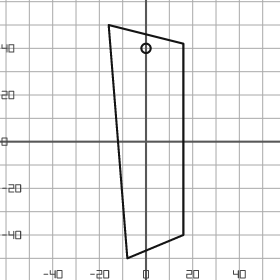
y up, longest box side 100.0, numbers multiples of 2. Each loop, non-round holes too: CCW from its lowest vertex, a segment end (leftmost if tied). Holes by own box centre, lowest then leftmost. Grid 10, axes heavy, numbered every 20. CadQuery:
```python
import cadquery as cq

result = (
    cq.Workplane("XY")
    .moveTo(-8.0, -50.0)
    .lineTo(16.0, -40.0)
    .lineTo(16.0, 42.0)
    .lineTo(-16.0, 50.0)
    .close()
    .moveTo(0.0, 40.0)
    .circle(2.0)
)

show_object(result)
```